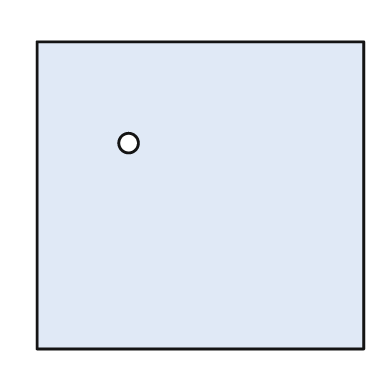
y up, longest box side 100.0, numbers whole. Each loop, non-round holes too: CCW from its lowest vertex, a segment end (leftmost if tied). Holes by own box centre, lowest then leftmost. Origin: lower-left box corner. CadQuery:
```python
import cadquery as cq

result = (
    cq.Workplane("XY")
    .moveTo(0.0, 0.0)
    .lineTo(100.0, 0.0)
    .lineTo(100.0, 94.0)
    .lineTo(0.0, 94.0)
    .close()
    .moveTo(28.0, 63.0)
    .circle(3.0)
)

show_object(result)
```